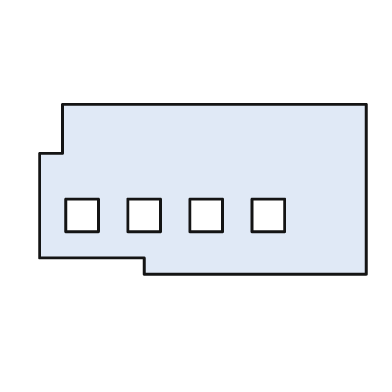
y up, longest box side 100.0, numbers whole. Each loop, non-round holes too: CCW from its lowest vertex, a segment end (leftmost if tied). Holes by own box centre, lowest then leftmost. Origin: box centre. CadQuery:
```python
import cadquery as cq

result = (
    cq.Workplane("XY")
    .moveTo(-18.0, -26.0)
    .lineTo(50.0, -26.0)
    .lineTo(50.0, 26.0)
    .lineTo(-43.0, 26.0)
    .lineTo(-43.0, 11.0)
    .lineTo(-50.0, 11.0)
    .lineTo(-50.0, -21.0)
    .lineTo(-18.0, -21.0)
    .close()
    .moveTo(-42.0, -13.0)
    .lineTo(-32.0, -13.0)
    .lineTo(-32.0, -3.0)
    .lineTo(-42.0, -3.0)
    .close()
    .moveTo(-23.0, -13.0)
    .lineTo(-13.0, -13.0)
    .lineTo(-13.0, -3.0)
    .lineTo(-23.0, -3.0)
    .close()
    .moveTo(-4.0, -13.0)
    .lineTo(6.0, -13.0)
    .lineTo(6.0, -3.0)
    .lineTo(-4.0, -3.0)
    .close()
    .moveTo(15.0, -13.0)
    .lineTo(25.0, -13.0)
    .lineTo(25.0, -3.0)
    .lineTo(15.0, -3.0)
    .close()
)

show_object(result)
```